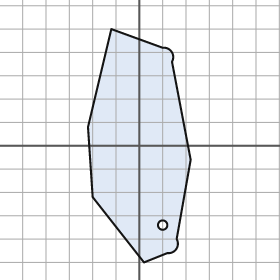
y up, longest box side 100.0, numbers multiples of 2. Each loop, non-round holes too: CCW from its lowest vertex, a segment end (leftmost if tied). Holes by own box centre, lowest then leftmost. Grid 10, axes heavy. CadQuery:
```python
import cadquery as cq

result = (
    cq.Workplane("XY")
    .moveTo(2.0, -50.0)
    .lineTo(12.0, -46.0)
    .threePointArc((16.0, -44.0), (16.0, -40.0))
    .lineTo(22.0, -6.0)
    .lineTo(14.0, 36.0)
    .threePointArc((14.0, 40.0), (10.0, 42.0))
    .lineTo(-12.0, 50.0)
    .lineTo(-22.0, 8.0)
    .lineTo(-20.0, -22.0)
    .close()
    .moveTo(10.0, -34.0)
    .circle(2.0)
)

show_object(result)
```